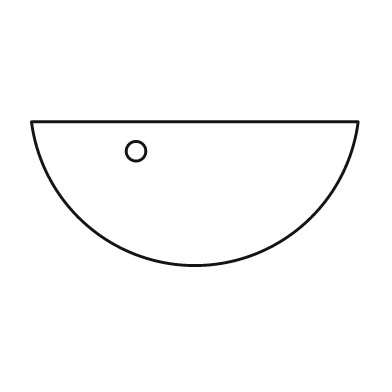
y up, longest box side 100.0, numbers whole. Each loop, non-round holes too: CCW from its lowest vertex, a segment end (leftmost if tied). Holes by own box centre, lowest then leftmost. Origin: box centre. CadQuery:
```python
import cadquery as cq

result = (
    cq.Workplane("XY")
    .moveTo(-50.0, 22.0)
    .threePointArc((0.0, -22.0), (50.0, 22.0))
    .close()
    .moveTo(-18.0, 13.0)
    .circle(3.0)
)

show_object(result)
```